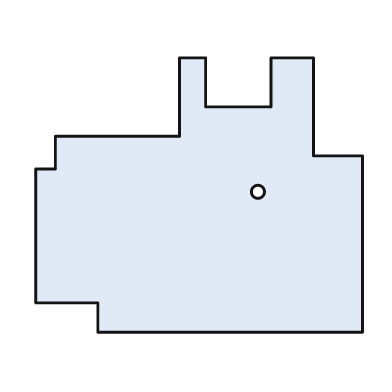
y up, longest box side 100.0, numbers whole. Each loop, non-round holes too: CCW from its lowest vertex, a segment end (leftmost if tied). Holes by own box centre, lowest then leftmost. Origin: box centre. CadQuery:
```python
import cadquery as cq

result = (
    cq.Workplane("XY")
    .moveTo(-31.0, -42.0)
    .lineTo(50.0, -42.0)
    .lineTo(50.0, 12.0)
    .lineTo(35.0, 12.0)
    .lineTo(35.0, 42.0)
    .lineTo(22.0, 42.0)
    .lineTo(22.0, 27.0)
    .lineTo(2.0, 27.0)
    .lineTo(2.0, 42.0)
    .lineTo(-6.0, 42.0)
    .lineTo(-6.0, 18.0)
    .lineTo(-44.0, 18.0)
    .lineTo(-44.0, 8.0)
    .lineTo(-50.0, 8.0)
    .lineTo(-50.0, -33.0)
    .lineTo(-31.0, -33.0)
    .close()
    .moveTo(18.0, 1.0)
    .circle(2.0)
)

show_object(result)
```